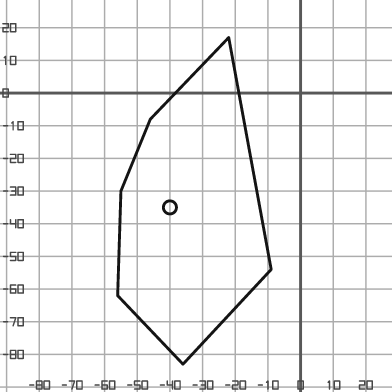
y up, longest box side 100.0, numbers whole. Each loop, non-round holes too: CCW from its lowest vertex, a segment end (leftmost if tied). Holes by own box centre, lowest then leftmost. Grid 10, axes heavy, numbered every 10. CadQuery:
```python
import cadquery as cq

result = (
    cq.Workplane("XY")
    .moveTo(-36.0, -83.0)
    .lineTo(-9.0, -54.0)
    .lineTo(-22.0, 17.0)
    .lineTo(-46.0, -8.0)
    .lineTo(-55.0, -30.0)
    .lineTo(-56.0, -62.0)
    .close()
    .moveTo(-40.0, -35.0)
    .circle(2.0)
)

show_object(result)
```